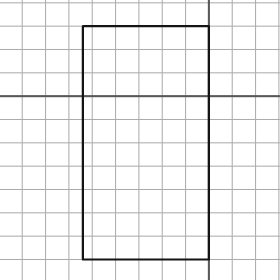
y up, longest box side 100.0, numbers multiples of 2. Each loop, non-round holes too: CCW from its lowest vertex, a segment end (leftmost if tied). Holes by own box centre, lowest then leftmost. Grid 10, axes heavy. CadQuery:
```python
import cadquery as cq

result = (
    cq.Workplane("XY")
    .moveTo(-54.0, -70.0)
    .lineTo(0.0, -70.0)
    .lineTo(0.0, 30.0)
    .lineTo(-54.0, 30.0)
    .close()
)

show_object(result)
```